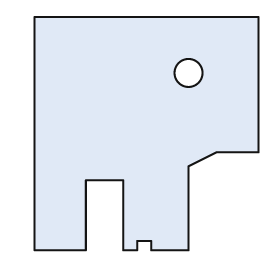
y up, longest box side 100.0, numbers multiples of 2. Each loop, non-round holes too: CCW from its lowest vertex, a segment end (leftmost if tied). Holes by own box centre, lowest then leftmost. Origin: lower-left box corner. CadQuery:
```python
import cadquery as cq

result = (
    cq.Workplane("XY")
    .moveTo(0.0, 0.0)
    .lineTo(22.0, 0.0)
    .lineTo(22.0, 30.0)
    .lineTo(38.0, 30.0)
    .lineTo(38.0, 0.0)
    .lineTo(44.0, 0.0)
    .lineTo(44.0, 4.0)
    .lineTo(50.0, 4.0)
    .lineTo(50.0, 0.0)
    .lineTo(66.0, 0.0)
    .lineTo(66.0, 36.0)
    .lineTo(78.0, 42.0)
    .lineTo(96.0, 42.0)
    .lineTo(96.0, 100.0)
    .lineTo(0.0, 100.0)
    .close()
    .moveTo(66.0, 76.0)
    .circle(6.0)
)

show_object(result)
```